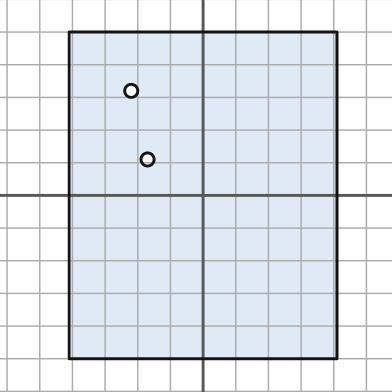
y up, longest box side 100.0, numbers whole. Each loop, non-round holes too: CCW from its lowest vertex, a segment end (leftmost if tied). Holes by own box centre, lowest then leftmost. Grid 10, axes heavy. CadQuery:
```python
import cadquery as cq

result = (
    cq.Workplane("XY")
    .moveTo(-41.0, -50.0)
    .lineTo(41.0, -50.0)
    .lineTo(41.0, 50.0)
    .lineTo(-41.0, 50.0)
    .close()
    .moveTo(-17.0, 11.0)
    .circle(2.0)
    .moveTo(-22.0, 32.0)
    .circle(2.0)
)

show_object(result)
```